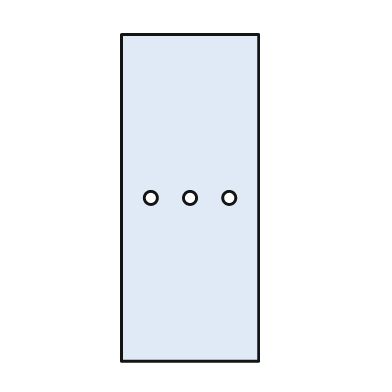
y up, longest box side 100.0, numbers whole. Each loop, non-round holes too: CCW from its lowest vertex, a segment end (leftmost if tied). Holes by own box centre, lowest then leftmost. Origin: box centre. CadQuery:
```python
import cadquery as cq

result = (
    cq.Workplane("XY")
    .moveTo(-21.0, -50.0)
    .lineTo(21.0, -50.0)
    .lineTo(21.0, 50.0)
    .lineTo(-21.0, 50.0)
    .close()
    .moveTo(-12.0, 0.0)
    .circle(2.0)
    .moveTo(0.0, 0.0)
    .circle(2.0)
    .moveTo(12.0, 0.0)
    .circle(2.0)
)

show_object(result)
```